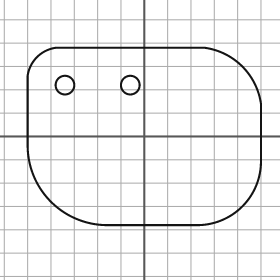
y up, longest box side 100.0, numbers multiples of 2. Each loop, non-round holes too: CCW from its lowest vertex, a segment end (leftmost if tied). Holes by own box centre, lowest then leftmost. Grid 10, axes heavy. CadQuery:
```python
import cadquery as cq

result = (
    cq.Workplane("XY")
    .moveTo(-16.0, -38.0)
    .lineTo(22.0, -38.0)
    .threePointArc((42.0, -30.0), (50.0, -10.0))
    .lineTo(50.0, 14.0)
    .threePointArc((42.0, 30.0), (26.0, 38.0))
    .lineTo(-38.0, 38.0)
    .threePointArc((-46.0, 34.0), (-50.0, 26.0))
    .lineTo(-50.0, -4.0)
    .threePointArc((-40.0, -28.0), (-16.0, -38.0))
    .close()
    .moveTo(-34.0, 22.0)
    .circle(4.0)
    .moveTo(-6.0, 22.0)
    .circle(4.0)
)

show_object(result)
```